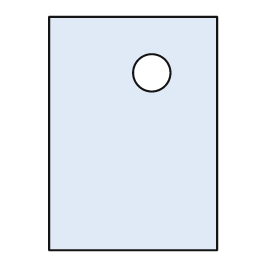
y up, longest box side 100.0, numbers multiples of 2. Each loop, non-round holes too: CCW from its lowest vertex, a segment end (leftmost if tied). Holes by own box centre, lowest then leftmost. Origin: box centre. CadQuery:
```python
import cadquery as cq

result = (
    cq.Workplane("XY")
    .moveTo(-36.0, -50.0)
    .lineTo(36.0, -50.0)
    .lineTo(36.0, 50.0)
    .lineTo(-36.0, 50.0)
    .close()
    .moveTo(8.0, 26.0)
    .circle(8.0)
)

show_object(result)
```